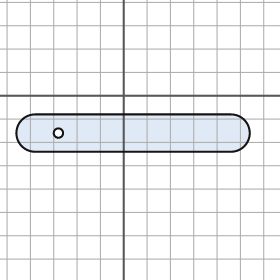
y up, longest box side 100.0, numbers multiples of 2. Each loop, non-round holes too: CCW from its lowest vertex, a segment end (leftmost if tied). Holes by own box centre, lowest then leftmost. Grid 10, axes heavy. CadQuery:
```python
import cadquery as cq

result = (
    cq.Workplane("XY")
    .moveTo(-38.0, -24.0)
    .lineTo(46.0, -24.0)
    .threePointArc((54.0, -16.0), (46.0, -8.0))
    .lineTo(-38.0, -8.0)
    .threePointArc((-46.0, -16.0), (-38.0, -24.0))
    .close()
    .moveTo(-28.0, -16.0)
    .circle(2.0)
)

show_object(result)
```